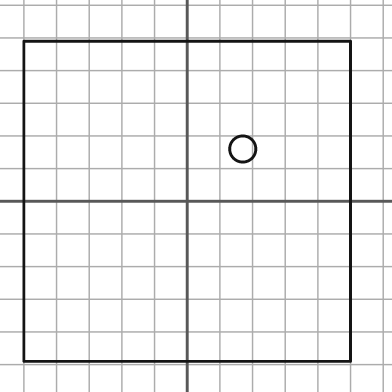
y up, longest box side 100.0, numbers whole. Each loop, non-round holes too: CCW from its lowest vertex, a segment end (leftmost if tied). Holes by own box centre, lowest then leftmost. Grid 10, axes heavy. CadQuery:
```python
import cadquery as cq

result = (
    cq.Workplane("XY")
    .moveTo(-50.0, -49.0)
    .lineTo(50.0, -49.0)
    .lineTo(50.0, 49.0)
    .lineTo(-50.0, 49.0)
    .close()
    .moveTo(17.0, 16.0)
    .circle(4.0)
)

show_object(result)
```